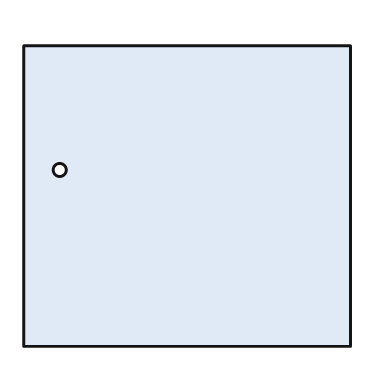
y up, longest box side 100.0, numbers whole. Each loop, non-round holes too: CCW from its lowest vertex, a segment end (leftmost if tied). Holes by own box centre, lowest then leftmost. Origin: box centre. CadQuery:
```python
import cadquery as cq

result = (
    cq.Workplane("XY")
    .moveTo(-50.0, -46.0)
    .lineTo(50.0, -46.0)
    .lineTo(50.0, 46.0)
    .lineTo(-50.0, 46.0)
    .close()
    .moveTo(-39.0, 8.0)
    .circle(2.0)
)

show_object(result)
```